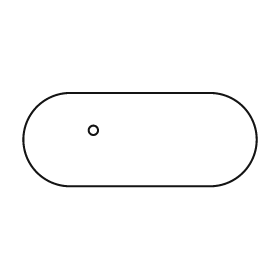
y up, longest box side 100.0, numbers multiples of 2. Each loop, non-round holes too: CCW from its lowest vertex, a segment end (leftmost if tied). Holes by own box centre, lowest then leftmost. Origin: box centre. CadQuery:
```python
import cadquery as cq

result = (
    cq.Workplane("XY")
    .moveTo(-30.0, -20.0)
    .lineTo(30.0, -20.0)
    .threePointArc((50.0, 0.0), (30.0, 20.0))
    .lineTo(-30.0, 20.0)
    .threePointArc((-50.0, 0.0), (-30.0, -20.0))
    .close()
    .moveTo(-20.0, 4.0)
    .circle(2.0)
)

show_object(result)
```